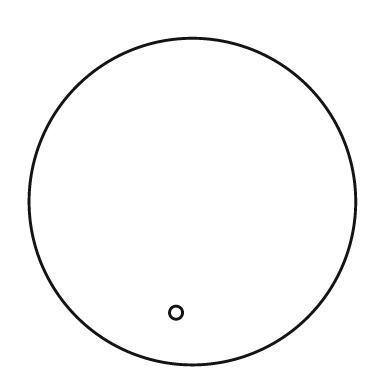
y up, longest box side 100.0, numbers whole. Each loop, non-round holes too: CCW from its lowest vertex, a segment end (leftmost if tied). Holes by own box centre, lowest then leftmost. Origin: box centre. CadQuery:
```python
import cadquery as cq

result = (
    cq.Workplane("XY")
    .moveTo(0.0, 0.0)
    .circle(50.0)
    .moveTo(-5.0, -34.0)
    .circle(2.0)
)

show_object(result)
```